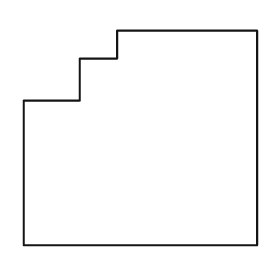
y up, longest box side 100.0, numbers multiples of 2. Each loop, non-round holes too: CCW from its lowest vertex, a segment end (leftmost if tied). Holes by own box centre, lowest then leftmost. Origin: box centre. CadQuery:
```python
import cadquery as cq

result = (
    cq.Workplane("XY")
    .moveTo(-50.0, -46.0)
    .lineTo(50.0, -46.0)
    .lineTo(50.0, 46.0)
    .lineTo(-10.0, 46.0)
    .lineTo(-10.0, 34.0)
    .lineTo(-26.0, 34.0)
    .lineTo(-26.0, 16.0)
    .lineTo(-50.0, 16.0)
    .close()
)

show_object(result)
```